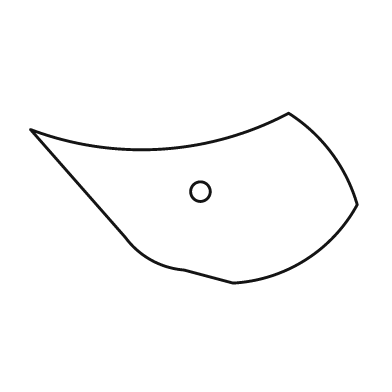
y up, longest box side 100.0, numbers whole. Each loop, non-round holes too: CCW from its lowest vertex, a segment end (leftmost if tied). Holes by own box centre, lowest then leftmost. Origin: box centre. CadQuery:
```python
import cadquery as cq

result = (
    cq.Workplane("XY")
    .moveTo(12.0, -26.0)
    .threePointArc((34.0, -19.0), (50.0, -2.0))
    .threePointArc((42.0, 14.0), (29.0, 26.0))
    .threePointArc((-10.0, 15.0), (-50.0, 21.0))
    .lineTo(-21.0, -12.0)
    .threePointArc((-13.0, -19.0), (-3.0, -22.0))
    .close()
    .moveTo(2.0, 2.0)
    .circle(3.0)
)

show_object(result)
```